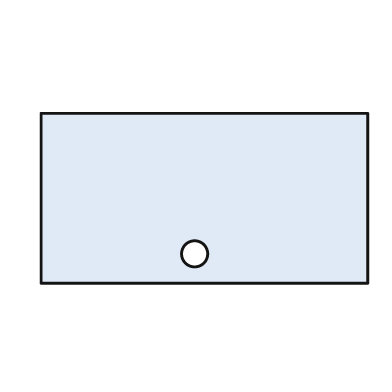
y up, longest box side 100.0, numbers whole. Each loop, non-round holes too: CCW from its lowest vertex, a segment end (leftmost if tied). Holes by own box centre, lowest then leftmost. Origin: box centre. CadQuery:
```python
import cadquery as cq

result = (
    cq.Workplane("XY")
    .moveTo(-50.0, -26.0)
    .lineTo(50.0, -26.0)
    .lineTo(50.0, 26.0)
    .lineTo(-50.0, 26.0)
    .close()
    .moveTo(-3.0, -17.0)
    .circle(4.0)
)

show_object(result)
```